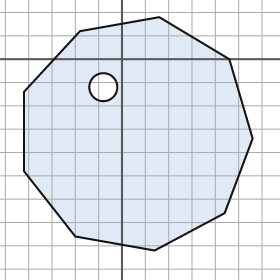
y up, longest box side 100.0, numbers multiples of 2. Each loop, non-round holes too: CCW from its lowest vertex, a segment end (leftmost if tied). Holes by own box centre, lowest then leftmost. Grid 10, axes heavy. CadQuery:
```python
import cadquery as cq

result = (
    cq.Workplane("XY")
    .moveTo(14.0, -82.0)
    .lineTo(44.0, -66.0)
    .lineTo(56.0, -34.0)
    .lineTo(46.0, 0.0)
    .lineTo(16.0, 18.0)
    .lineTo(-18.0, 12.0)
    .lineTo(-42.0, -14.0)
    .lineTo(-42.0, -48.0)
    .lineTo(-20.0, -76.0)
    .close()
    .moveTo(-8.0, -12.0)
    .circle(6.0)
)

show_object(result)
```